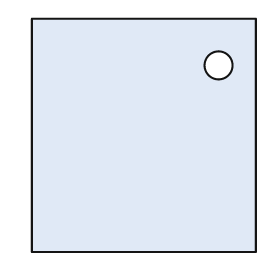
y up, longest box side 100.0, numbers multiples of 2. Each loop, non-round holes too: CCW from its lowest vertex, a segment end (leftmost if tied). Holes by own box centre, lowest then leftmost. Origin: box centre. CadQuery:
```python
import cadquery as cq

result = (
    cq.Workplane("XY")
    .moveTo(-48.0, -50.0)
    .lineTo(48.0, -50.0)
    .lineTo(48.0, 50.0)
    .lineTo(-48.0, 50.0)
    .close()
    .moveTo(32.0, 30.0)
    .circle(6.0)
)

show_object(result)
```